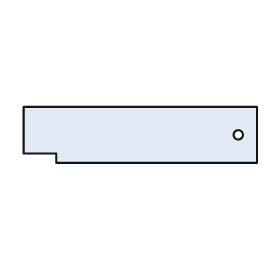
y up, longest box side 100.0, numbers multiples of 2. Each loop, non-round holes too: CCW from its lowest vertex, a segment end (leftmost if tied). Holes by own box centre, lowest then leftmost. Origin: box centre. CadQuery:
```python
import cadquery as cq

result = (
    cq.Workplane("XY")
    .moveTo(-36.0, -12.0)
    .lineTo(50.0, -12.0)
    .lineTo(50.0, 12.0)
    .lineTo(-50.0, 12.0)
    .lineTo(-50.0, -8.0)
    .lineTo(-36.0, -8.0)
    .close()
    .moveTo(42.0, 0.0)
    .circle(2.0)
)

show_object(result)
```